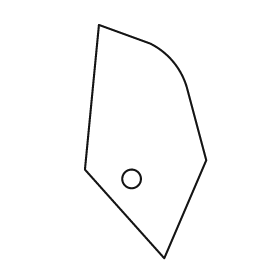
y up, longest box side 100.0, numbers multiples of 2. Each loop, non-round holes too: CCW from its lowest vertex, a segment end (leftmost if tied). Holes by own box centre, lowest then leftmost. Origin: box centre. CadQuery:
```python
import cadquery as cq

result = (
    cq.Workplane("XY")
    .moveTo(8.0, -50.0)
    .lineTo(26.0, -8.0)
    .lineTo(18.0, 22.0)
    .threePointArc((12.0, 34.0), (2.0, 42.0))
    .lineTo(-20.0, 50.0)
    .lineTo(-26.0, -12.0)
    .close()
    .moveTo(-6.0, -16.0)
    .circle(4.0)
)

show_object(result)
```